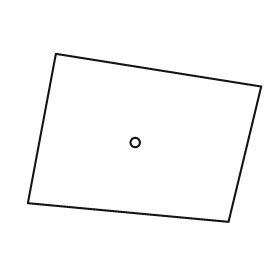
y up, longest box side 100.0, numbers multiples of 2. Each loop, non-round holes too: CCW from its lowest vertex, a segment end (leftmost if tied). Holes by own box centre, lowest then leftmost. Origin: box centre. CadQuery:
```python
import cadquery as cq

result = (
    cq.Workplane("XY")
    .moveTo(36.0, -36.0)
    .lineTo(50.0, 22.0)
    .lineTo(-38.0, 36.0)
    .lineTo(-50.0, -28.0)
    .close()
    .moveTo(-4.0, -2.0)
    .circle(2.0)
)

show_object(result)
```